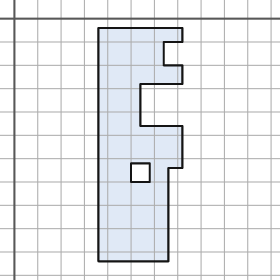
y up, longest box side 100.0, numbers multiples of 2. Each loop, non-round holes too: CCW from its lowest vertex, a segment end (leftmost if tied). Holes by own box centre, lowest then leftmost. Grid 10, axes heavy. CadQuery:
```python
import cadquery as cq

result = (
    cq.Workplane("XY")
    .moveTo(36.0, -104.0)
    .lineTo(66.0, -104.0)
    .lineTo(66.0, -64.0)
    .lineTo(72.0, -64.0)
    .lineTo(72.0, -46.0)
    .lineTo(54.0, -46.0)
    .lineTo(54.0, -28.0)
    .lineTo(72.0, -28.0)
    .lineTo(72.0, -20.0)
    .lineTo(64.0, -20.0)
    .lineTo(64.0, -10.0)
    .lineTo(72.0, -10.0)
    .lineTo(72.0, -4.0)
    .lineTo(36.0, -4.0)
    .close()
    .moveTo(50.0, -70.0)
    .lineTo(58.0, -70.0)
    .lineTo(58.0, -62.0)
    .lineTo(50.0, -62.0)
    .close()
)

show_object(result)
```